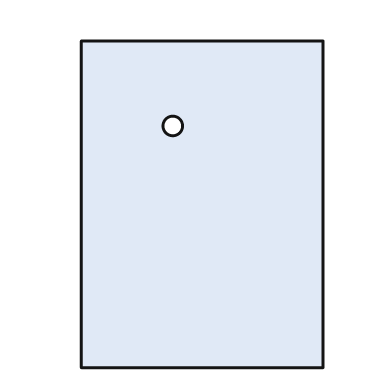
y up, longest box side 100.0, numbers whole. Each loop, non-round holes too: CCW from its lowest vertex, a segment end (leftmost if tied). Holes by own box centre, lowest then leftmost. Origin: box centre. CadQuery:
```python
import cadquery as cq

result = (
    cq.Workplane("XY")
    .moveTo(-37.0, -50.0)
    .lineTo(37.0, -50.0)
    .lineTo(37.0, 50.0)
    .lineTo(-37.0, 50.0)
    .close()
    .moveTo(-9.0, 24.0)
    .circle(3.0)
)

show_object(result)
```